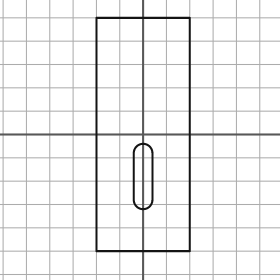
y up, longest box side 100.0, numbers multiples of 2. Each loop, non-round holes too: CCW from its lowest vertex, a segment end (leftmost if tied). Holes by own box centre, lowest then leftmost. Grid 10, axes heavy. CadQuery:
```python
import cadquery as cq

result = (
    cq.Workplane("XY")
    .moveTo(-20.0, -50.0)
    .lineTo(20.0, -50.0)
    .lineTo(20.0, 50.0)
    .lineTo(-20.0, 50.0)
    .close()
    .moveTo(-4.0, -28.0)
    .threePointArc((0.0, -32.0), (4.0, -28.0))
    .lineTo(4.0, -8.0)
    .threePointArc((0.0, -4.0), (-4.0, -8.0))
    .close()
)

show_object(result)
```